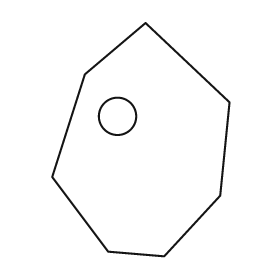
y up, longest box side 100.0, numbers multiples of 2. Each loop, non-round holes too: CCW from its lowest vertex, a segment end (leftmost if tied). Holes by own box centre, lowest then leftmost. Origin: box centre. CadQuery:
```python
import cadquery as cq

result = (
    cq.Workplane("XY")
    .moveTo(10.0, -50.0)
    .lineTo(34.0, -24.0)
    .lineTo(38.0, 16.0)
    .lineTo(2.0, 50.0)
    .lineTo(-24.0, 28.0)
    .lineTo(-38.0, -16.0)
    .lineTo(-14.0, -48.0)
    .close()
    .moveTo(-10.0, 10.0)
    .circle(8.0)
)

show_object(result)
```